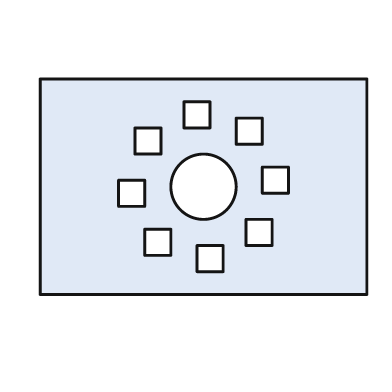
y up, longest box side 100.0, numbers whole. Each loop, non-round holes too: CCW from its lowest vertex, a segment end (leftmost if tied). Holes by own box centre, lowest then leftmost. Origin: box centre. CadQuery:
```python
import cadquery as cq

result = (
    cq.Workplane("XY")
    .moveTo(-50.0, -33.0)
    .lineTo(50.0, -33.0)
    .lineTo(50.0, 33.0)
    .lineTo(-50.0, 33.0)
    .close()
    .moveTo(-2.0, -26.0)
    .lineTo(6.0, -26.0)
    .lineTo(6.0, -18.0)
    .lineTo(-2.0, -18.0)
    .close()
    .moveTo(-18.0, -21.0)
    .lineTo(-10.0, -21.0)
    .lineTo(-10.0, -13.0)
    .lineTo(-18.0, -13.0)
    .close()
    .moveTo(13.0, -18.0)
    .lineTo(21.0, -18.0)
    .lineTo(21.0, -10.0)
    .lineTo(13.0, -10.0)
    .close()
    .moveTo(-26.0, -6.0)
    .lineTo(-18.0, -6.0)
    .lineTo(-18.0, 2.0)
    .lineTo(-26.0, 2.0)
    .close()
    .moveTo(0.0, 0.0)
    .circle(10.0)
    .moveTo(18.0, -2.0)
    .lineTo(26.0, -2.0)
    .lineTo(26.0, 6.0)
    .lineTo(18.0, 6.0)
    .close()
    .moveTo(-21.0, 10.0)
    .lineTo(-13.0, 10.0)
    .lineTo(-13.0, 18.0)
    .lineTo(-21.0, 18.0)
    .close()
    .moveTo(10.0, 13.0)
    .lineTo(18.0, 13.0)
    .lineTo(18.0, 21.0)
    .lineTo(10.0, 21.0)
    .close()
    .moveTo(-6.0, 18.0)
    .lineTo(2.0, 18.0)
    .lineTo(2.0, 26.0)
    .lineTo(-6.0, 26.0)
    .close()
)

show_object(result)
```